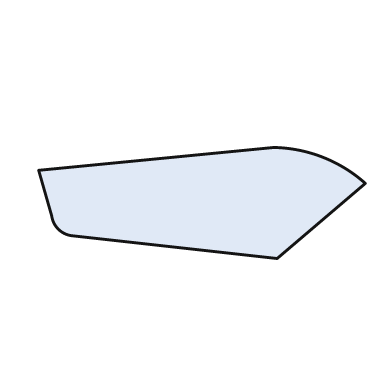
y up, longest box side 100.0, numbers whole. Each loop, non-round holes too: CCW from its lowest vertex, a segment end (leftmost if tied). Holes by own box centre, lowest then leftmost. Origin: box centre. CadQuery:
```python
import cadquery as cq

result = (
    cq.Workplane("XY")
    .moveTo(23.0, -17.0)
    .lineTo(50.0, 6.0)
    .threePointArc((37.0, 14.0), (22.0, 17.0))
    .lineTo(-50.0, 10.0)
    .lineTo(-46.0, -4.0)
    .threePointArc((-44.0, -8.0), (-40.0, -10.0))
    .close()
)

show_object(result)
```